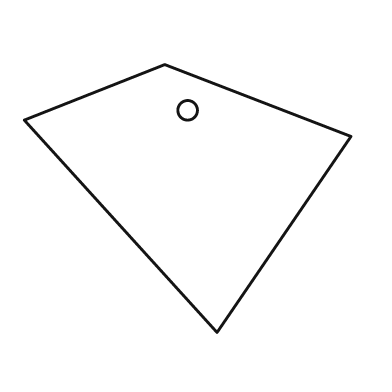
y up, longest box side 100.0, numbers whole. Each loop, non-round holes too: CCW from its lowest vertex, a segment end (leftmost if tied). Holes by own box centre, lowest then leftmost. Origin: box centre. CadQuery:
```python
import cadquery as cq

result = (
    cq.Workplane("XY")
    .moveTo(9.0, -41.0)
    .lineTo(50.0, 19.0)
    .lineTo(-7.0, 41.0)
    .lineTo(-50.0, 24.0)
    .close()
    .moveTo(0.0, 27.0)
    .circle(3.0)
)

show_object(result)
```